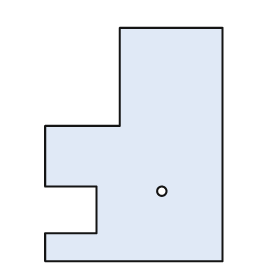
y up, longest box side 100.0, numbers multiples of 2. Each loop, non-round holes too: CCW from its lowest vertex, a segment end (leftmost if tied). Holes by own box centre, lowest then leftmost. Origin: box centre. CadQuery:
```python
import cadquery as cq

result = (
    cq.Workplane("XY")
    .moveTo(-38.0, -50.0)
    .lineTo(38.0, -50.0)
    .lineTo(38.0, 50.0)
    .lineTo(-6.0, 50.0)
    .lineTo(-6.0, 8.0)
    .lineTo(-38.0, 8.0)
    .lineTo(-38.0, -18.0)
    .lineTo(-16.0, -18.0)
    .lineTo(-16.0, -38.0)
    .lineTo(-38.0, -38.0)
    .close()
    .moveTo(12.0, -20.0)
    .circle(2.0)
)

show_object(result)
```